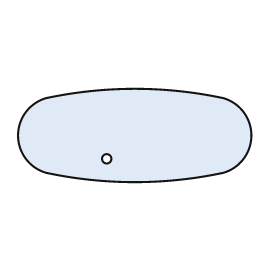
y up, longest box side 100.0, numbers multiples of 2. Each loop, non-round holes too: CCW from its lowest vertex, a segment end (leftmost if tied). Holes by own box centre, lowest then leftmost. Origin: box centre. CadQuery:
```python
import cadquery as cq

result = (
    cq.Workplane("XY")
    .moveTo(-38.0, -16.0)
    .threePointArc((0.0, -20.0), (38.0, -16.0))
    .threePointArc((50.0, 0.0), (38.0, 16.0))
    .threePointArc((0.0, 20.0), (-38.0, 16.0))
    .threePointArc((-50.0, 0.0), (-38.0, -16.0))
    .close()
    .moveTo(-12.0, -10.0)
    .circle(2.0)
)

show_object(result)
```